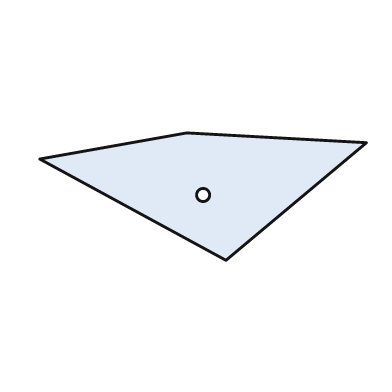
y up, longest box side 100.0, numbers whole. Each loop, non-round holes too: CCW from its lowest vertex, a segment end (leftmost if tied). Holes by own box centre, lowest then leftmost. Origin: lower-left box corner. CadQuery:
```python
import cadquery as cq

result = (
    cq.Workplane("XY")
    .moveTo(57.0, 0.0)
    .lineTo(100.0, 36.0)
    .lineTo(45.0, 39.0)
    .lineTo(0.0, 31.0)
    .close()
    .moveTo(50.0, 20.0)
    .circle(2.0)
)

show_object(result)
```